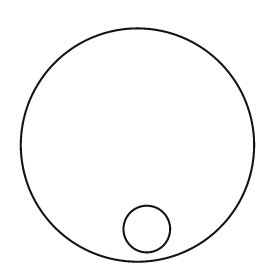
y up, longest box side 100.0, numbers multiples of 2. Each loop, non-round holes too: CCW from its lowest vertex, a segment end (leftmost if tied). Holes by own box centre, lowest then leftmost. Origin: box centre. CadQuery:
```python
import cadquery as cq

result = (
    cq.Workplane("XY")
    .moveTo(0.0, 0.0)
    .circle(50.0)
    .moveTo(4.0, -36.0)
    .circle(10.0)
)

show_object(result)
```